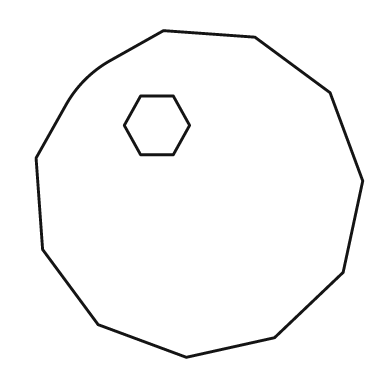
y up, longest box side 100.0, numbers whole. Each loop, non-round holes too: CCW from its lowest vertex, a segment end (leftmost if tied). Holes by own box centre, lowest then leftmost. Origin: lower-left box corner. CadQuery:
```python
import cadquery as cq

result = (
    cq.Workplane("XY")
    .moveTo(46.0, 0.0)
    .lineTo(73.0, 6.0)
    .lineTo(94.0, 26.0)
    .lineTo(100.0, 54.0)
    .lineTo(90.0, 81.0)
    .lineTo(67.0, 98.0)
    .lineTo(39.0, 100.0)
    .lineTo(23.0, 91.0)
    .threePointArc((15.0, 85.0), (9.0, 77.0))
    .lineTo(0.0, 61.0)
    .lineTo(2.0, 33.0)
    .lineTo(19.0, 10.0)
    .close()
    .moveTo(32.0, 62.0)
    .lineTo(42.0, 62.0)
    .lineTo(47.0, 71.0)
    .lineTo(42.0, 80.0)
    .lineTo(32.0, 80.0)
    .lineTo(27.0, 71.0)
    .close()
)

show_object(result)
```